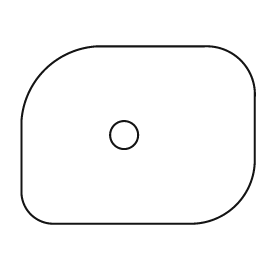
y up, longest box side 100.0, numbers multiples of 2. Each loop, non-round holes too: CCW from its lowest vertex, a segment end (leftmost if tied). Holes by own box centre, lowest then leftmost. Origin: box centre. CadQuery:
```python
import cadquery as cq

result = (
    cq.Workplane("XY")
    .moveTo(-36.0, -38.0)
    .lineTo(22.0, -38.0)
    .threePointArc((42.0, -30.0), (50.0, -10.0))
    .lineTo(50.0, 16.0)
    .threePointArc((44.0, 32.0), (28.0, 38.0))
    .lineTo(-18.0, 38.0)
    .threePointArc((-40.0, 28.0), (-50.0, 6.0))
    .lineTo(-50.0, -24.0)
    .threePointArc((-46.0, -34.0), (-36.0, -38.0))
    .close()
    .moveTo(-6.0, 0.0)
    .circle(6.0)
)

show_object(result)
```